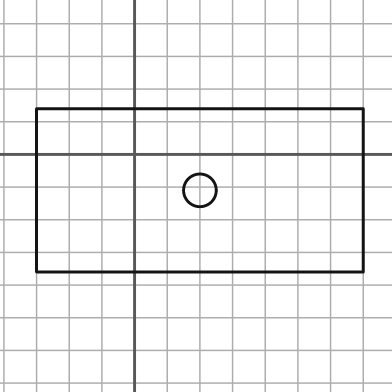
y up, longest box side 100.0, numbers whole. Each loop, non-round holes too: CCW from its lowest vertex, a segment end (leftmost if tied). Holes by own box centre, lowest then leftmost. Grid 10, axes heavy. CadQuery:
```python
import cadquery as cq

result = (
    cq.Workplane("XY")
    .moveTo(-30.0, -36.0)
    .lineTo(70.0, -36.0)
    .lineTo(70.0, 14.0)
    .lineTo(-30.0, 14.0)
    .close()
    .moveTo(20.0, -11.0)
    .circle(5.0)
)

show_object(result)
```